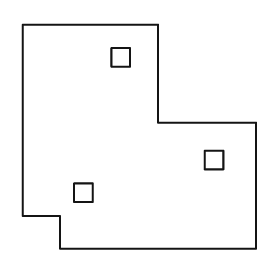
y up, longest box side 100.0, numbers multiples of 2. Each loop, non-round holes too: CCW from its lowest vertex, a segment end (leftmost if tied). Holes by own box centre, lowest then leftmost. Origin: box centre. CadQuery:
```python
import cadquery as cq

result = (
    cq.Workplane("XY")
    .moveTo(-34.0, -48.0)
    .lineTo(50.0, -48.0)
    .lineTo(50.0, 6.0)
    .lineTo(8.0, 6.0)
    .lineTo(8.0, 48.0)
    .lineTo(-50.0, 48.0)
    .lineTo(-50.0, -34.0)
    .lineTo(-34.0, -34.0)
    .close()
    .moveTo(-28.0, -28.0)
    .lineTo(-20.0, -28.0)
    .lineTo(-20.0, -20.0)
    .lineTo(-28.0, -20.0)
    .close()
    .moveTo(28.0, -14.0)
    .lineTo(36.0, -14.0)
    .lineTo(36.0, -6.0)
    .lineTo(28.0, -6.0)
    .close()
    .moveTo(-12.0, 30.0)
    .lineTo(-4.0, 30.0)
    .lineTo(-4.0, 38.0)
    .lineTo(-12.0, 38.0)
    .close()
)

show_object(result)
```